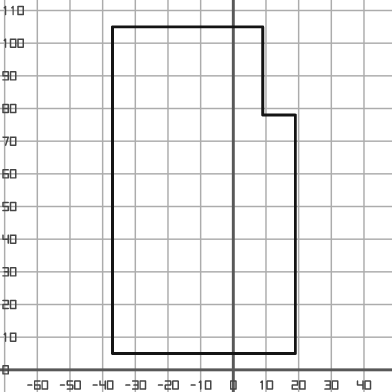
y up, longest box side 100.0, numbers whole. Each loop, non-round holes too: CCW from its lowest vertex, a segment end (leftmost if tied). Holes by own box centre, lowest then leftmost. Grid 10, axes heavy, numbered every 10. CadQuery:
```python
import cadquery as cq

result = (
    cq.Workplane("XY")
    .moveTo(-37.0, 5.0)
    .lineTo(19.0, 5.0)
    .lineTo(19.0, 78.0)
    .lineTo(9.0, 78.0)
    .lineTo(9.0, 105.0)
    .lineTo(-37.0, 105.0)
    .close()
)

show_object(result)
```